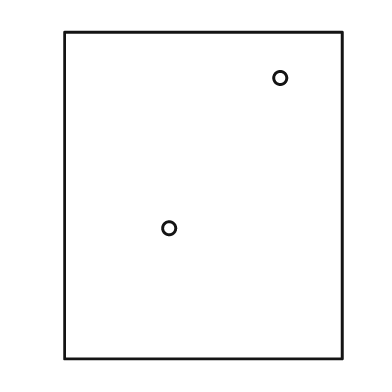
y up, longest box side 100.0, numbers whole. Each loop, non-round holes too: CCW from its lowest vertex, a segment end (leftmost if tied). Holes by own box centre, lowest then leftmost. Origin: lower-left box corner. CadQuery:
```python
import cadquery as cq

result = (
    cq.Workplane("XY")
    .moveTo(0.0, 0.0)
    .lineTo(85.0, 0.0)
    .lineTo(85.0, 100.0)
    .lineTo(0.0, 100.0)
    .close()
    .moveTo(32.0, 40.0)
    .circle(2.0)
    .moveTo(66.0, 86.0)
    .circle(2.0)
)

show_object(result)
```